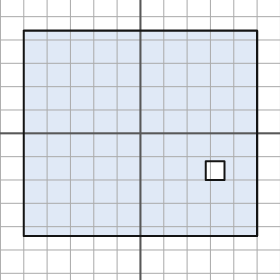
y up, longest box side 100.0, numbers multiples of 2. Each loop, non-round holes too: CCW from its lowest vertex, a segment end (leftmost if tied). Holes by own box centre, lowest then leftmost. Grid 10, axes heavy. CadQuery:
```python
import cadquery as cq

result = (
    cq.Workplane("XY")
    .moveTo(-50.0, -44.0)
    .lineTo(50.0, -44.0)
    .lineTo(50.0, 44.0)
    .lineTo(-50.0, 44.0)
    .close()
    .moveTo(28.0, -20.0)
    .lineTo(36.0, -20.0)
    .lineTo(36.0, -12.0)
    .lineTo(28.0, -12.0)
    .close()
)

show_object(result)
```